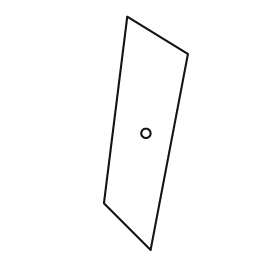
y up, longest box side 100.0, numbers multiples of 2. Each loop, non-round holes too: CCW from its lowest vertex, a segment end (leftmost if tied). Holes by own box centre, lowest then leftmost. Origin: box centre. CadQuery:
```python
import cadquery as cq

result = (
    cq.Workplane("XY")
    .moveTo(2.0, -50.0)
    .lineTo(18.0, 34.0)
    .lineTo(-8.0, 50.0)
    .lineTo(-18.0, -30.0)
    .close()
    .moveTo(0.0, 0.0)
    .circle(2.0)
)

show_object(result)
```